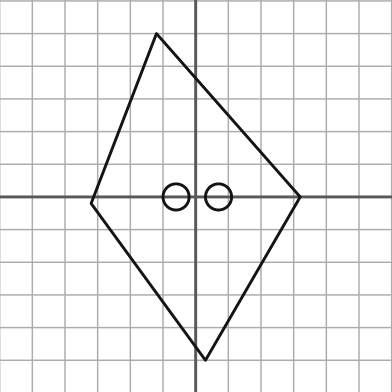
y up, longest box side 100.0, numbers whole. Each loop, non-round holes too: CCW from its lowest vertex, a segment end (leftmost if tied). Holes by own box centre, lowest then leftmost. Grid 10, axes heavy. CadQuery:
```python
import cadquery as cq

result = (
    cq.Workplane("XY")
    .moveTo(3.0, -50.0)
    .lineTo(32.0, 0.0)
    .lineTo(-12.0, 50.0)
    .lineTo(-32.0, -2.0)
    .close()
    .moveTo(-6.0, 0.0)
    .circle(4.0)
    .moveTo(7.0, 0.0)
    .circle(4.0)
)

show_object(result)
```